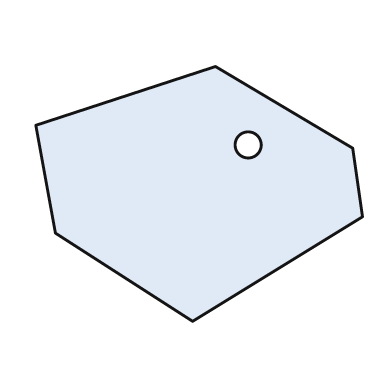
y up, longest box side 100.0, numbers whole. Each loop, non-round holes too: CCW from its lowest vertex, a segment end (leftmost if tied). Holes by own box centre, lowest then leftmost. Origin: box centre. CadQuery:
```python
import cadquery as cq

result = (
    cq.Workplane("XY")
    .moveTo(-2.0, -39.0)
    .lineTo(50.0, -7.0)
    .lineTo(47.0, 14.0)
    .lineTo(5.0, 39.0)
    .lineTo(-50.0, 21.0)
    .lineTo(-44.0, -12.0)
    .close()
    .moveTo(15.0, 15.0)
    .circle(4.0)
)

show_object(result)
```